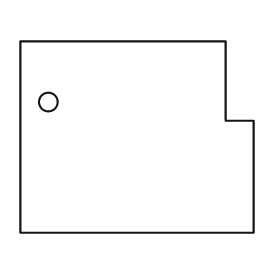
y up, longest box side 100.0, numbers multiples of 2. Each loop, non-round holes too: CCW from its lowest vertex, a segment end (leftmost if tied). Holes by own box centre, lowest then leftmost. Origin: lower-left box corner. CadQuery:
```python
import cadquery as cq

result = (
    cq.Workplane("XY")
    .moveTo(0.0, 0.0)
    .lineTo(100.0, 0.0)
    .lineTo(100.0, 48.0)
    .lineTo(88.0, 48.0)
    .lineTo(88.0, 82.0)
    .lineTo(0.0, 82.0)
    .close()
    .moveTo(12.0, 56.0)
    .circle(4.0)
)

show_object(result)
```